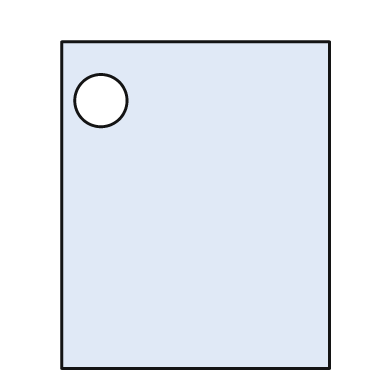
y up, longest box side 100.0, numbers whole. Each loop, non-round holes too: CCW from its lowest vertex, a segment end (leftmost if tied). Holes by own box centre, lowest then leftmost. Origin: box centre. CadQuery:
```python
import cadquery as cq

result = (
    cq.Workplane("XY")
    .moveTo(-41.0, -50.0)
    .lineTo(41.0, -50.0)
    .lineTo(41.0, 50.0)
    .lineTo(-41.0, 50.0)
    .close()
    .moveTo(-29.0, 32.0)
    .circle(8.0)
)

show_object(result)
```